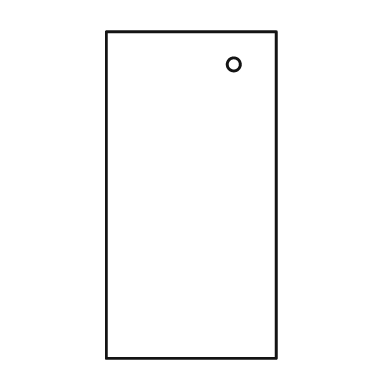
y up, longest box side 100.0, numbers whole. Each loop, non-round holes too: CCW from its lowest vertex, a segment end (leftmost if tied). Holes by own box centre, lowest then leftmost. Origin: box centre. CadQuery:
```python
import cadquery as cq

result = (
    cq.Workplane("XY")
    .moveTo(-26.0, -50.0)
    .lineTo(26.0, -50.0)
    .lineTo(26.0, 50.0)
    .lineTo(-26.0, 50.0)
    .close()
    .moveTo(13.0, 40.0)
    .circle(2.0)
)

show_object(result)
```